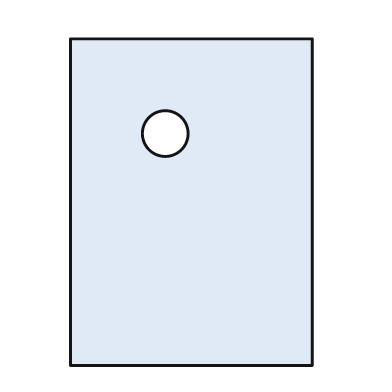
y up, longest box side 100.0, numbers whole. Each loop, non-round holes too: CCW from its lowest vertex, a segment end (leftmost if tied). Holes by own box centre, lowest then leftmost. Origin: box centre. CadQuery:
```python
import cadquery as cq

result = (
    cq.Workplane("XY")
    .moveTo(-37.0, -50.0)
    .lineTo(37.0, -50.0)
    .lineTo(37.0, 50.0)
    .lineTo(-37.0, 50.0)
    .close()
    .moveTo(-8.0, 21.0)
    .circle(7.0)
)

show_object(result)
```